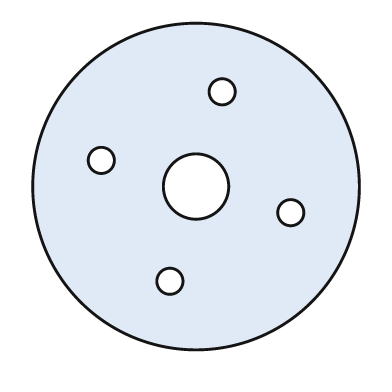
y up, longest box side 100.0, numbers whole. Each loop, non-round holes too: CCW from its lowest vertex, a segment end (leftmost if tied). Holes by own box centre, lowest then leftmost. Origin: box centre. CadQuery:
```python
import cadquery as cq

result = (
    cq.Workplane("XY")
    .moveTo(0.0, 0.0)
    .circle(50.0)
    .moveTo(-8.0, -29.0)
    .circle(4.0)
    .moveTo(29.0, -8.0)
    .circle(4.0)
    .moveTo(0.0, 0.0)
    .circle(10.0)
    .moveTo(-29.0, 8.0)
    .circle(4.0)
    .moveTo(8.0, 29.0)
    .circle(4.0)
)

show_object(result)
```